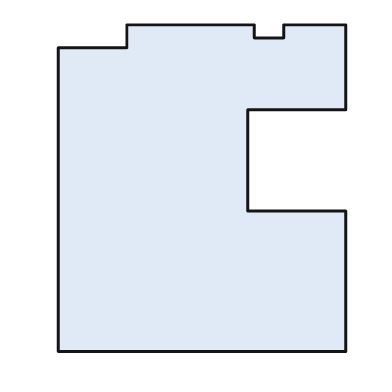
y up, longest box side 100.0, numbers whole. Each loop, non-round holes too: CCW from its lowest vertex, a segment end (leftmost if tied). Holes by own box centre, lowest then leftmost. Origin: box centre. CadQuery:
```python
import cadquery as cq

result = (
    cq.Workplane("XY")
    .moveTo(-44.0, -50.0)
    .lineTo(44.0, -50.0)
    .lineTo(44.0, -7.0)
    .lineTo(14.0, -7.0)
    .lineTo(14.0, 24.0)
    .lineTo(44.0, 24.0)
    .lineTo(44.0, 50.0)
    .lineTo(25.0, 50.0)
    .lineTo(25.0, 46.0)
    .lineTo(16.0, 46.0)
    .lineTo(16.0, 50.0)
    .lineTo(-23.0, 50.0)
    .lineTo(-23.0, 43.0)
    .lineTo(-44.0, 43.0)
    .close()
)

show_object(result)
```